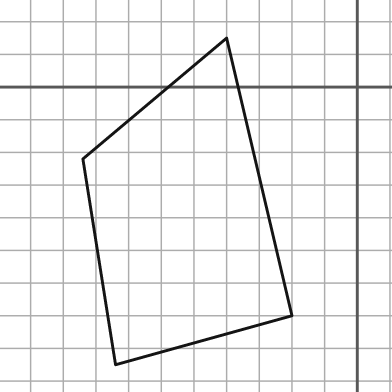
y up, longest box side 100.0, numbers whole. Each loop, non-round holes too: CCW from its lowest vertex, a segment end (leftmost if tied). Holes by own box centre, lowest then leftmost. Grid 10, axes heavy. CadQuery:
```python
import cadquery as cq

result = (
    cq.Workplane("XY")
    .moveTo(-74.0, -85.0)
    .lineTo(-20.0, -70.0)
    .lineTo(-40.0, 15.0)
    .lineTo(-84.0, -22.0)
    .close()
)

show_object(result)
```